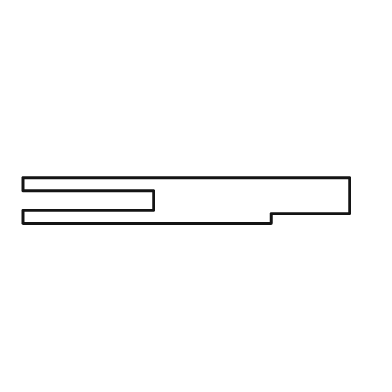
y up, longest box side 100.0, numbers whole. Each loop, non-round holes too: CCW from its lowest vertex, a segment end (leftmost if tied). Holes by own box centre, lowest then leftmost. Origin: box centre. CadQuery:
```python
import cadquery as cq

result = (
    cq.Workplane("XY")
    .moveTo(-50.0, -7.0)
    .lineTo(26.0, -7.0)
    .lineTo(26.0, -4.0)
    .lineTo(50.0, -4.0)
    .lineTo(50.0, 7.0)
    .lineTo(-50.0, 7.0)
    .lineTo(-50.0, 3.0)
    .lineTo(-10.0, 3.0)
    .lineTo(-10.0, -3.0)
    .lineTo(-50.0, -3.0)
    .close()
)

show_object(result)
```